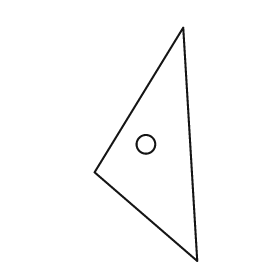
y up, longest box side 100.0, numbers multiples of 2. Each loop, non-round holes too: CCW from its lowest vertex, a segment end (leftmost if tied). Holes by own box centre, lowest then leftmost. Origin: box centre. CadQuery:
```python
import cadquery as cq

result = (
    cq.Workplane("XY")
    .moveTo(22.0, -50.0)
    .lineTo(16.0, 50.0)
    .lineTo(-22.0, -12.0)
    .close()
    .moveTo(0.0, 0.0)
    .circle(4.0)
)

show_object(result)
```